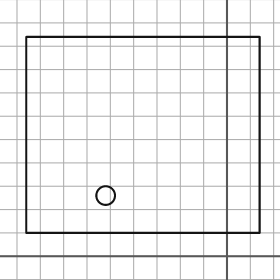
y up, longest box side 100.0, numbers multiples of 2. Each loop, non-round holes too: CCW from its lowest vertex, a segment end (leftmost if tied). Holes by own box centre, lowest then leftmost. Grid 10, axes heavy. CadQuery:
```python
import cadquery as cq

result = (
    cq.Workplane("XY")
    .moveTo(-86.0, 10.0)
    .lineTo(14.0, 10.0)
    .lineTo(14.0, 94.0)
    .lineTo(-86.0, 94.0)
    .close()
    .moveTo(-52.0, 26.0)
    .circle(4.0)
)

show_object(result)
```